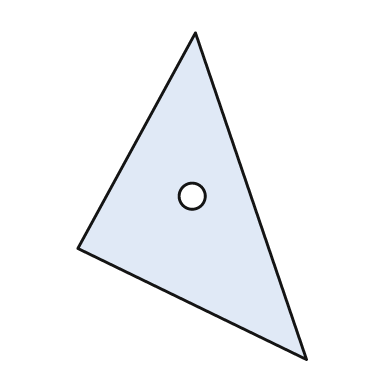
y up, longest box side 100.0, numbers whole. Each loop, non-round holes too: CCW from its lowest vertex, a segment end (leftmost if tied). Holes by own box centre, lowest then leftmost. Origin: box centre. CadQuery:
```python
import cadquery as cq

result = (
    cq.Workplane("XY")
    .moveTo(35.0, -50.0)
    .lineTo(1.0, 50.0)
    .lineTo(-35.0, -16.0)
    .close()
    .moveTo(0.0, 0.0)
    .circle(4.0)
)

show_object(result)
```